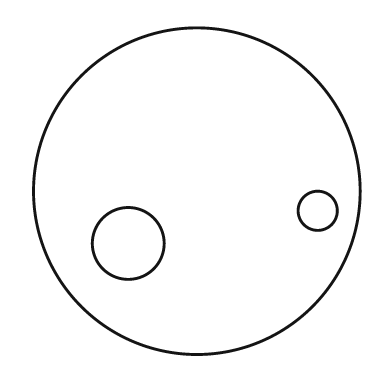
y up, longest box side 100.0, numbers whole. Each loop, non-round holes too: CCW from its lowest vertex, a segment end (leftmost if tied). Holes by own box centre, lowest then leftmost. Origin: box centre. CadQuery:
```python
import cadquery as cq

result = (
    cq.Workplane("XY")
    .moveTo(0.0, 0.0)
    .circle(50.0)
    .moveTo(-21.0, -16.0)
    .circle(11.0)
    .moveTo(37.0, -6.0)
    .circle(6.0)
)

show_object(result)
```